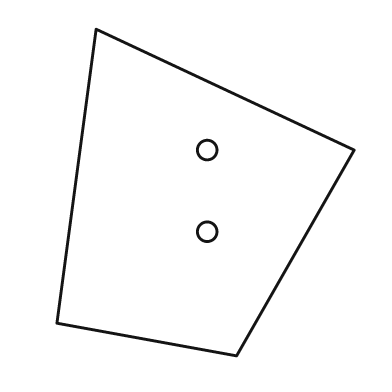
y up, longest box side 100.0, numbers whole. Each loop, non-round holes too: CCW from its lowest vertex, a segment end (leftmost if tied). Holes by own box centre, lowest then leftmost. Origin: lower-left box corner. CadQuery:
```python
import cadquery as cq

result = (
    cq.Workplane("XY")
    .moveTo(55.0, 0.0)
    .lineTo(91.0, 63.0)
    .lineTo(12.0, 100.0)
    .lineTo(0.0, 10.0)
    .close()
    .moveTo(46.0, 38.0)
    .circle(3.0)
    .moveTo(46.0, 63.0)
    .circle(3.0)
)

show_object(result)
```